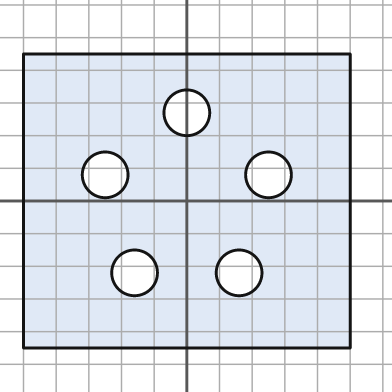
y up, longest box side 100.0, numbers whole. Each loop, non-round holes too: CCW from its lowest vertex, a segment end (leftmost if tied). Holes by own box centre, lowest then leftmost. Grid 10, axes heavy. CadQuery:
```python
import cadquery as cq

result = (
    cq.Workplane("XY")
    .moveTo(-50.0, -45.0)
    .lineTo(50.0, -45.0)
    .lineTo(50.0, 45.0)
    .lineTo(-50.0, 45.0)
    .close()
    .moveTo(-16.0, -22.0)
    .circle(7.0)
    .moveTo(16.0, -22.0)
    .circle(7.0)
    .moveTo(-25.0, 8.0)
    .circle(7.0)
    .moveTo(25.0, 8.0)
    .circle(7.0)
    .moveTo(0.0, 27.0)
    .circle(7.0)
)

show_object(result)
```